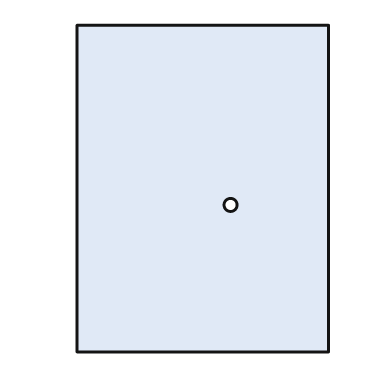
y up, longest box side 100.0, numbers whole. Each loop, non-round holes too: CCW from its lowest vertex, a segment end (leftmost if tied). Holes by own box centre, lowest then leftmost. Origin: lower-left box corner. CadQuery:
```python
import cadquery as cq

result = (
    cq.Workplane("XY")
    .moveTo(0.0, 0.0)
    .lineTo(77.0, 0.0)
    .lineTo(77.0, 100.0)
    .lineTo(0.0, 100.0)
    .close()
    .moveTo(47.0, 45.0)
    .circle(2.0)
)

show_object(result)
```